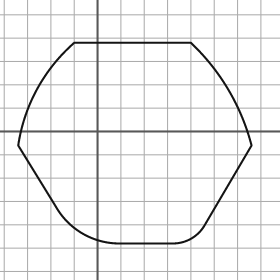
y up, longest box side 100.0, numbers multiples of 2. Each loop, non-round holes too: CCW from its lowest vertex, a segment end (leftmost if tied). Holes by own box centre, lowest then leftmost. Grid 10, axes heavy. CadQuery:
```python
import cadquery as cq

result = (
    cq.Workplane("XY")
    .moveTo(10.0, -48.0)
    .lineTo(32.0, -48.0)
    .threePointArc((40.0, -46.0), (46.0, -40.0))
    .lineTo(66.0, -6.0)
    .threePointArc((56.0, 18.0), (40.0, 38.0))
    .lineTo(-10.0, 38.0)
    .threePointArc((-26.0, 18.0), (-34.0, -6.0))
    .lineTo(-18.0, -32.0)
    .threePointArc((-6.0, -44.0), (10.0, -48.0))
    .close()
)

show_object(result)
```